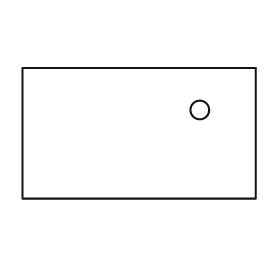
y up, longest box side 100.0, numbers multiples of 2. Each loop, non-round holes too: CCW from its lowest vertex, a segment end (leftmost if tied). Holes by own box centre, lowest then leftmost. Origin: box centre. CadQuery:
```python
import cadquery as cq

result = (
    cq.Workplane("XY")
    .moveTo(-50.0, -28.0)
    .lineTo(50.0, -28.0)
    .lineTo(50.0, 28.0)
    .lineTo(-50.0, 28.0)
    .close()
    .moveTo(26.0, 10.0)
    .circle(4.0)
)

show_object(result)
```